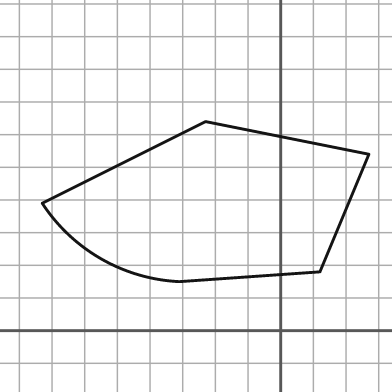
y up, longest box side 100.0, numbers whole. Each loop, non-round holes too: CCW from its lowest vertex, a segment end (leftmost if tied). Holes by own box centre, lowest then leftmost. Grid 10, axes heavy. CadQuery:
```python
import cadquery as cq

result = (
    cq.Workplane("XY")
    .moveTo(-31.0, 15.0)
    .lineTo(12.0, 18.0)
    .lineTo(27.0, 54.0)
    .lineTo(-23.0, 64.0)
    .lineTo(-73.0, 39.0)
    .threePointArc((-55.0, 22.0), (-31.0, 15.0))
    .close()
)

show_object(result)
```